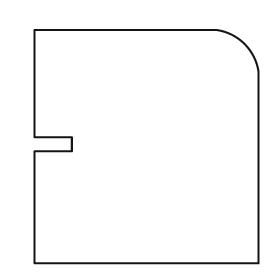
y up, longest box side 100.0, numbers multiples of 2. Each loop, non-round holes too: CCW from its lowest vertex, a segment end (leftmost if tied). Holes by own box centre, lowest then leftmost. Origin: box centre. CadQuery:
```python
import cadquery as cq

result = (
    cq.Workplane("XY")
    .moveTo(-48.0, -50.0)
    .lineTo(48.0, -50.0)
    .lineTo(48.0, 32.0)
    .threePointArc((42.0, 44.0), (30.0, 50.0))
    .lineTo(-48.0, 50.0)
    .lineTo(-48.0, 4.0)
    .lineTo(-32.0, 4.0)
    .lineTo(-32.0, -2.0)
    .lineTo(-48.0, -2.0)
    .close()
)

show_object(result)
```